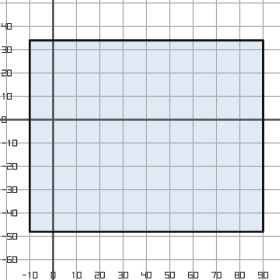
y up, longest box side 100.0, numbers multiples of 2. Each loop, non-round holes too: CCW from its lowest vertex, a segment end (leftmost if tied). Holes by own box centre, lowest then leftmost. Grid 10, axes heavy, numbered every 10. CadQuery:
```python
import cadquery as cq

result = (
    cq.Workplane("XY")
    .moveTo(-10.0, -48.0)
    .lineTo(90.0, -48.0)
    .lineTo(90.0, 34.0)
    .lineTo(-10.0, 34.0)
    .close()
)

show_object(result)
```